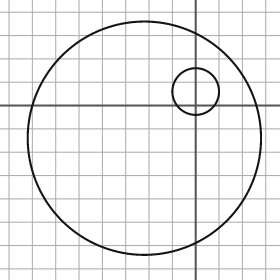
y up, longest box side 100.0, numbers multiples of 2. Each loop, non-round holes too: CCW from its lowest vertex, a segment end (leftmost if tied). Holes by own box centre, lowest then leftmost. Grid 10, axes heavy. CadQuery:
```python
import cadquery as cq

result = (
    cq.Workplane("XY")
    .moveTo(-22.0, -14.0)
    .circle(50.0)
    .moveTo(0.0, 6.0)
    .circle(10.0)
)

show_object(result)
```